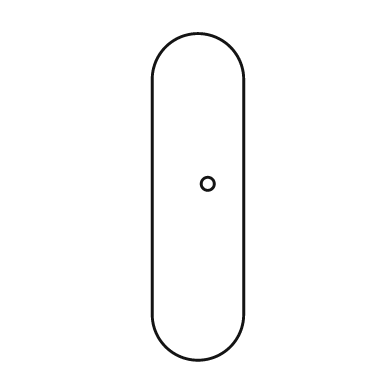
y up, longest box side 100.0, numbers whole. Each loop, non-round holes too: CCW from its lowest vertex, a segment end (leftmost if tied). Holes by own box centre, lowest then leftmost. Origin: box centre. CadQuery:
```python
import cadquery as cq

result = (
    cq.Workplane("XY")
    .moveTo(-14.0, -36.0)
    .threePointArc((0.0, -50.0), (14.0, -36.0))
    .lineTo(14.0, 36.0)
    .threePointArc((0.0, 50.0), (-14.0, 36.0))
    .close()
    .moveTo(3.0, 4.0)
    .circle(2.0)
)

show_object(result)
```